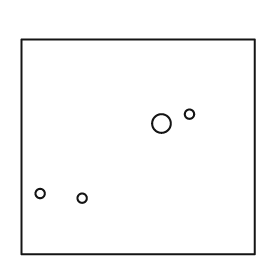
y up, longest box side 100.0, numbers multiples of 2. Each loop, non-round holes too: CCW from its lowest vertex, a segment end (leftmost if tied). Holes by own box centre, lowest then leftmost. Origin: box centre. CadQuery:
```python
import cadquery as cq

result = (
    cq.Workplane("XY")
    .moveTo(-50.0, -46.0)
    .lineTo(50.0, -46.0)
    .lineTo(50.0, 46.0)
    .lineTo(-50.0, 46.0)
    .close()
    .moveTo(-24.0, -22.0)
    .circle(2.0)
    .moveTo(-42.0, -20.0)
    .circle(2.0)
    .moveTo(10.0, 10.0)
    .circle(4.0)
    .moveTo(22.0, 14.0)
    .circle(2.0)
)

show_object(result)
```